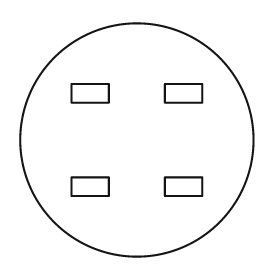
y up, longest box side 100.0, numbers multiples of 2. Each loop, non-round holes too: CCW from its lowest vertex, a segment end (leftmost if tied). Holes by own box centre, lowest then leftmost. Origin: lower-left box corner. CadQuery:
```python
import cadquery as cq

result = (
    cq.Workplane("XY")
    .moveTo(50.0, 50.0)
    .circle(50.0)
    .moveTo(22.0, 26.0)
    .lineTo(38.0, 26.0)
    .lineTo(38.0, 34.0)
    .lineTo(22.0, 34.0)
    .close()
    .moveTo(62.0, 26.0)
    .lineTo(78.0, 26.0)
    .lineTo(78.0, 34.0)
    .lineTo(62.0, 34.0)
    .close()
    .moveTo(22.0, 66.0)
    .lineTo(38.0, 66.0)
    .lineTo(38.0, 74.0)
    .lineTo(22.0, 74.0)
    .close()
    .moveTo(62.0, 66.0)
    .lineTo(78.0, 66.0)
    .lineTo(78.0, 74.0)
    .lineTo(62.0, 74.0)
    .close()
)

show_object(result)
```